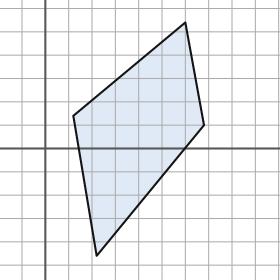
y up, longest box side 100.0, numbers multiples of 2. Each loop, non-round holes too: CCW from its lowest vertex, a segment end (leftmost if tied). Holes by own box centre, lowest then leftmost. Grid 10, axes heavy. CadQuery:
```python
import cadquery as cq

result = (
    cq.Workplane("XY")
    .moveTo(22.0, -46.0)
    .lineTo(68.0, 10.0)
    .lineTo(60.0, 54.0)
    .lineTo(12.0, 14.0)
    .close()
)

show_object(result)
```